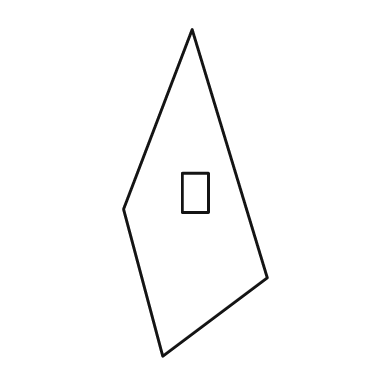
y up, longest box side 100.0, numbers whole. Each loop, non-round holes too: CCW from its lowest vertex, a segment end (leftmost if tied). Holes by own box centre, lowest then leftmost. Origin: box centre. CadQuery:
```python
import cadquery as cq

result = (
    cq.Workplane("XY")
    .moveTo(-10.0, -50.0)
    .lineTo(22.0, -26.0)
    .lineTo(-1.0, 50.0)
    .lineTo(-22.0, -5.0)
    .close()
    .moveTo(-4.0, -6.0)
    .lineTo(4.0, -6.0)
    .lineTo(4.0, 6.0)
    .lineTo(-4.0, 6.0)
    .close()
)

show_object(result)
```